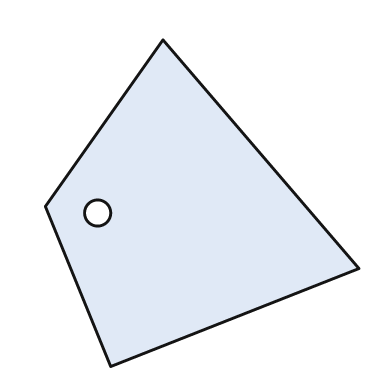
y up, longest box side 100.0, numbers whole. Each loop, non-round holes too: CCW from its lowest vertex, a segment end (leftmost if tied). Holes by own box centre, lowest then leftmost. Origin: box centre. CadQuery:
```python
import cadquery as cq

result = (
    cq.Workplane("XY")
    .moveTo(-28.0, -50.0)
    .lineTo(48.0, -20.0)
    .lineTo(-12.0, 50.0)
    .lineTo(-48.0, -1.0)
    .close()
    .moveTo(-32.0, -3.0)
    .circle(4.0)
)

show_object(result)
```